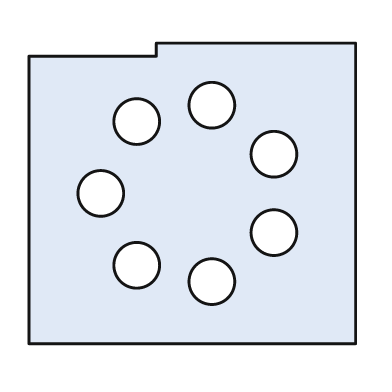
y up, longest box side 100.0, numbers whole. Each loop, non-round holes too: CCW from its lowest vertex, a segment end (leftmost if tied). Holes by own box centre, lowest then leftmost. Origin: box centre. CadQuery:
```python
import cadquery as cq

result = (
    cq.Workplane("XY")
    .moveTo(-50.0, -46.0)
    .lineTo(50.0, -46.0)
    .lineTo(50.0, 46.0)
    .lineTo(-11.0, 46.0)
    .lineTo(-11.0, 42.0)
    .lineTo(-50.0, 42.0)
    .close()
    .moveTo(6.0, -27.0)
    .circle(7.0)
    .moveTo(-17.0, -22.0)
    .circle(7.0)
    .moveTo(25.0, -12.0)
    .circle(7.0)
    .moveTo(-28.0, 0.0)
    .circle(7.0)
    .moveTo(25.0, 12.0)
    .circle(7.0)
    .moveTo(-17.0, 22.0)
    .circle(7.0)
    .moveTo(6.0, 27.0)
    .circle(7.0)
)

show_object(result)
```